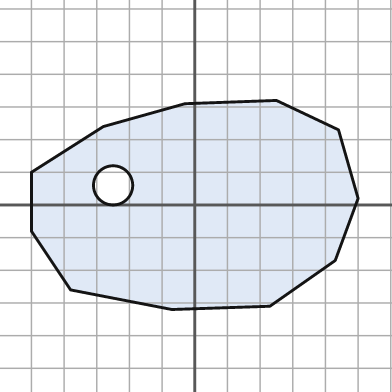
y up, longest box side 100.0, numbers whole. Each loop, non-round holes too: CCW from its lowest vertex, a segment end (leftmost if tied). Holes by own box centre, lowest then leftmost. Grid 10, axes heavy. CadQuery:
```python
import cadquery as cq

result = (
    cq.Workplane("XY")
    .moveTo(-7.0, -32.0)
    .lineTo(23.0, -31.0)
    .lineTo(43.0, -17.0)
    .lineTo(50.0, 2.0)
    .lineTo(44.0, 23.0)
    .lineTo(25.0, 32.0)
    .lineTo(-3.0, 31.0)
    .lineTo(-28.0, 24.0)
    .lineTo(-50.0, 10.0)
    .lineTo(-50.0, -8.0)
    .lineTo(-38.0, -26.0)
    .close()
    .moveTo(-25.0, 6.0)
    .circle(6.0)
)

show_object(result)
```